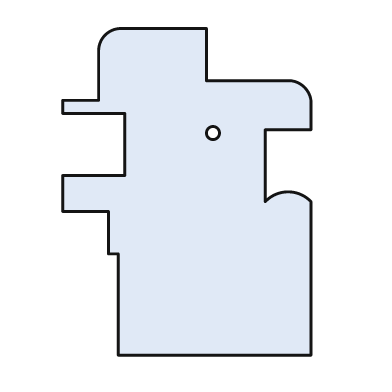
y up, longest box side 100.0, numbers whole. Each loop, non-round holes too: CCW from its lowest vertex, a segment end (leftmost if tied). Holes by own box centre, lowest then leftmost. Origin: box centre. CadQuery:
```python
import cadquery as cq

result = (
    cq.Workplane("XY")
    .moveTo(-21.0, -50.0)
    .lineTo(38.0, -50.0)
    .lineTo(38.0, -3.0)
    .threePointArc((31.0, 0.0), (24.0, -3.0))
    .lineTo(24.0, 19.0)
    .lineTo(38.0, 19.0)
    .lineTo(38.0, 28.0)
    .threePointArc((36.0, 32.0), (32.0, 34.0))
    .lineTo(6.0, 34.0)
    .lineTo(6.0, 50.0)
    .lineTo(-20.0, 50.0)
    .threePointArc((-25.0, 48.0), (-27.0, 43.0))
    .lineTo(-27.0, 28.0)
    .lineTo(-38.0, 28.0)
    .lineTo(-38.0, 24.0)
    .lineTo(-19.0, 24.0)
    .lineTo(-19.0, 5.0)
    .lineTo(-38.0, 5.0)
    .lineTo(-38.0, -6.0)
    .lineTo(-24.0, -6.0)
    .lineTo(-24.0, -19.0)
    .lineTo(-21.0, -19.0)
    .close()
    .moveTo(8.0, 18.0)
    .circle(2.0)
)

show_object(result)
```